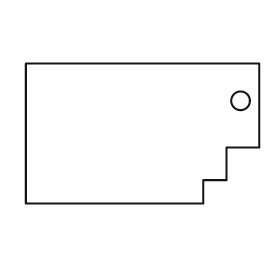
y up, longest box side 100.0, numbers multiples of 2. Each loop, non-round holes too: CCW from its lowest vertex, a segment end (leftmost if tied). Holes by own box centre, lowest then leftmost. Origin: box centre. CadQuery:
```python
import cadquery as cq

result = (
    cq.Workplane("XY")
    .moveTo(-50.0, -30.0)
    .lineTo(26.0, -30.0)
    .lineTo(26.0, -20.0)
    .lineTo(36.0, -20.0)
    .lineTo(36.0, -6.0)
    .lineTo(50.0, -6.0)
    .lineTo(50.0, 30.0)
    .lineTo(-50.0, 30.0)
    .close()
    .moveTo(42.0, 14.0)
    .circle(4.0)
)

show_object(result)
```